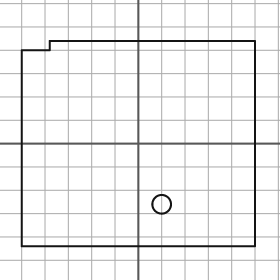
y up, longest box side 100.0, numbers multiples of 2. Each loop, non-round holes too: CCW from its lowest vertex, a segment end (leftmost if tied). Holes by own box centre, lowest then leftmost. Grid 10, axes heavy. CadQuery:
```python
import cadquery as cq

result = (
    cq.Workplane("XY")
    .moveTo(-50.0, -44.0)
    .lineTo(50.0, -44.0)
    .lineTo(50.0, 44.0)
    .lineTo(-38.0, 44.0)
    .lineTo(-38.0, 40.0)
    .lineTo(-50.0, 40.0)
    .close()
    .moveTo(10.0, -26.0)
    .circle(4.0)
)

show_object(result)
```